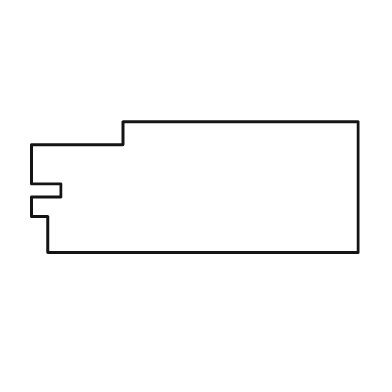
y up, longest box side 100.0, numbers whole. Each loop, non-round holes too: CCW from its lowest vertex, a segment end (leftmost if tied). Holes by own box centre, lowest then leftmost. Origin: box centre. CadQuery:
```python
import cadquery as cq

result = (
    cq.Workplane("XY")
    .moveTo(-45.0, -20.0)
    .lineTo(50.0, -20.0)
    .lineTo(50.0, 20.0)
    .lineTo(-22.0, 20.0)
    .lineTo(-22.0, 13.0)
    .lineTo(-50.0, 13.0)
    .lineTo(-50.0, 1.0)
    .lineTo(-41.0, 1.0)
    .lineTo(-41.0, -3.0)
    .lineTo(-50.0, -3.0)
    .lineTo(-50.0, -9.0)
    .lineTo(-45.0, -9.0)
    .close()
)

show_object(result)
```